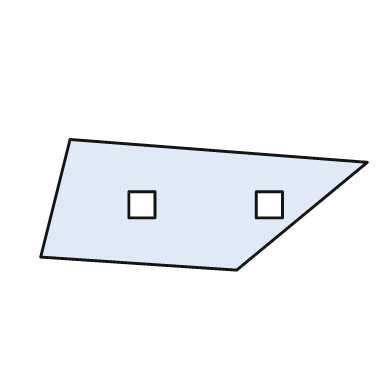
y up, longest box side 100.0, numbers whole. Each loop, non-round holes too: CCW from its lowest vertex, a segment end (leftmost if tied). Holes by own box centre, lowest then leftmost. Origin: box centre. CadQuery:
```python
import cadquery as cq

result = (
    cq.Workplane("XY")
    .moveTo(10.0, -20.0)
    .lineTo(50.0, 13.0)
    .lineTo(-41.0, 20.0)
    .lineTo(-50.0, -16.0)
    .close()
    .moveTo(-23.0, -4.0)
    .lineTo(-15.0, -4.0)
    .lineTo(-15.0, 4.0)
    .lineTo(-23.0, 4.0)
    .close()
    .moveTo(16.0, -4.0)
    .lineTo(24.0, -4.0)
    .lineTo(24.0, 4.0)
    .lineTo(16.0, 4.0)
    .close()
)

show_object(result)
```